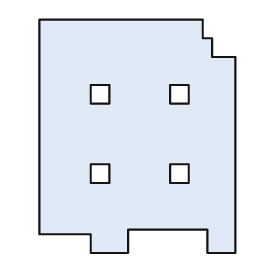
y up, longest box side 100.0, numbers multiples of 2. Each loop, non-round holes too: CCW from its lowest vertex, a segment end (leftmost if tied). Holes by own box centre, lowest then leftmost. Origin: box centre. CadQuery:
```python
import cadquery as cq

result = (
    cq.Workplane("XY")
    .moveTo(-20.0, -50.0)
    .lineTo(-4.0, -50.0)
    .lineTo(-4.0, -40.0)
    .lineTo(30.0, -40.0)
    .lineTo(30.0, -50.0)
    .lineTo(42.0, -50.0)
    .lineTo(42.0, 34.0)
    .lineTo(32.0, 34.0)
    .lineTo(32.0, 42.0)
    .lineTo(28.0, 42.0)
    .lineTo(28.0, 50.0)
    .lineTo(-42.0, 50.0)
    .lineTo(-42.0, -42.0)
    .lineTo(-20.0, -42.0)
    .close()
    .moveTo(-20.0, -20.0)
    .lineTo(-12.0, -20.0)
    .lineTo(-12.0, -12.0)
    .lineTo(-20.0, -12.0)
    .close()
    .moveTo(14.0, -20.0)
    .lineTo(22.0, -20.0)
    .lineTo(22.0, -12.0)
    .lineTo(14.0, -12.0)
    .close()
    .moveTo(-20.0, 14.0)
    .lineTo(-12.0, 14.0)
    .lineTo(-12.0, 22.0)
    .lineTo(-20.0, 22.0)
    .close()
    .moveTo(14.0, 14.0)
    .lineTo(22.0, 14.0)
    .lineTo(22.0, 22.0)
    .lineTo(14.0, 22.0)
    .close()
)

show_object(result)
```